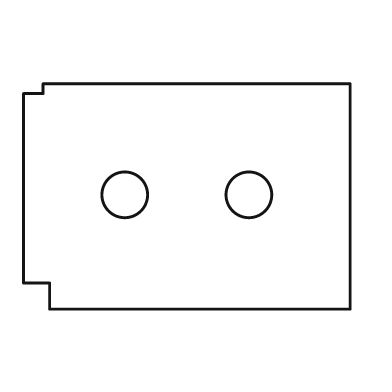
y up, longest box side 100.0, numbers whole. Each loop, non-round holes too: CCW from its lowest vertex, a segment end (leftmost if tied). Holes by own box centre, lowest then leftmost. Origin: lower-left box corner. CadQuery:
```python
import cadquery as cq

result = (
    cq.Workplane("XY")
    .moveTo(8.0, 0.0)
    .lineTo(100.0, 0.0)
    .lineTo(100.0, 69.0)
    .lineTo(6.0, 69.0)
    .lineTo(6.0, 66.0)
    .lineTo(0.0, 66.0)
    .lineTo(0.0, 8.0)
    .lineTo(8.0, 8.0)
    .close()
    .moveTo(31.0, 35.0)
    .circle(7.0)
    .moveTo(69.0, 35.0)
    .circle(7.0)
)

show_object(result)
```